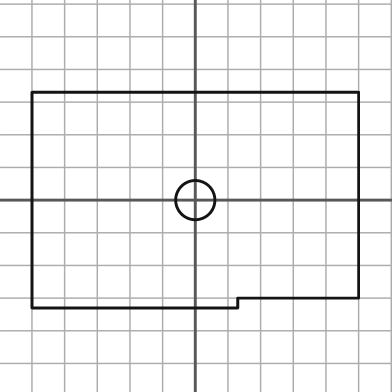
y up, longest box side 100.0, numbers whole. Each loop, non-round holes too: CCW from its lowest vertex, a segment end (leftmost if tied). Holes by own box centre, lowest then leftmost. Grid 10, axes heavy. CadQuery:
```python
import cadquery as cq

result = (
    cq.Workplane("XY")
    .moveTo(-50.0, -33.0)
    .lineTo(13.0, -33.0)
    .lineTo(13.0, -30.0)
    .lineTo(50.0, -30.0)
    .lineTo(50.0, 33.0)
    .lineTo(-50.0, 33.0)
    .close()
    .moveTo(0.0, 0.0)
    .circle(6.0)
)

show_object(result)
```